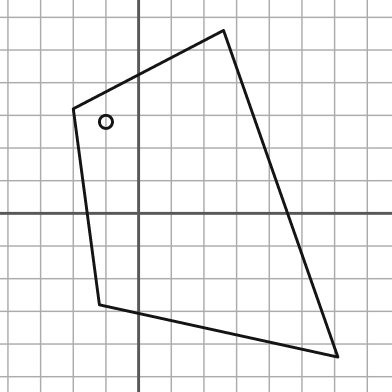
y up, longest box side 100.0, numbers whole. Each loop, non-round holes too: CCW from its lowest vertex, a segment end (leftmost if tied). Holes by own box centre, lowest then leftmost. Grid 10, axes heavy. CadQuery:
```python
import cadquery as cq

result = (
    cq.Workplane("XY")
    .moveTo(61.0, -44.0)
    .lineTo(26.0, 56.0)
    .lineTo(-20.0, 32.0)
    .lineTo(-12.0, -28.0)
    .close()
    .moveTo(-10.0, 28.0)
    .circle(2.0)
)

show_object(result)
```